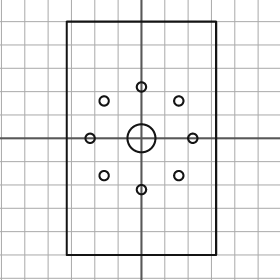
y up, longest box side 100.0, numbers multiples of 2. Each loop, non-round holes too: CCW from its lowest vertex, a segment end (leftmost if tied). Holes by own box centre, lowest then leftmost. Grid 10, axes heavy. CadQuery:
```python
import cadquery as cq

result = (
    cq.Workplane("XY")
    .moveTo(-32.0, -50.0)
    .lineTo(32.0, -50.0)
    .lineTo(32.0, 50.0)
    .lineTo(-32.0, 50.0)
    .close()
    .moveTo(0.0, -22.0)
    .circle(2.0)
    .moveTo(-16.0, -16.0)
    .circle(2.0)
    .moveTo(16.0, -16.0)
    .circle(2.0)
    .moveTo(-22.0, 0.0)
    .circle(2.0)
    .moveTo(0.0, 0.0)
    .circle(6.0)
    .moveTo(22.0, 0.0)
    .circle(2.0)
    .moveTo(-16.0, 16.0)
    .circle(2.0)
    .moveTo(16.0, 16.0)
    .circle(2.0)
    .moveTo(0.0, 22.0)
    .circle(2.0)
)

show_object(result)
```